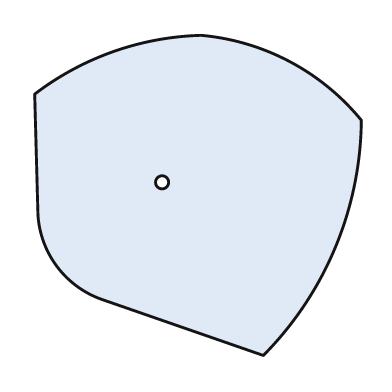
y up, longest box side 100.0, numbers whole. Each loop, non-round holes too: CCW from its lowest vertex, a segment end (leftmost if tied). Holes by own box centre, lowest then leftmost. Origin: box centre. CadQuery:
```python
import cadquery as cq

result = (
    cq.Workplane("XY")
    .moveTo(20.0, -49.0)
    .threePointArc((42.0, -16.0), (50.0, 23.0))
    .threePointArc((28.0, 41.0), (1.0, 49.0))
    .threePointArc((-26.0, 44.0), (-50.0, 31.0))
    .lineTo(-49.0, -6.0)
    .threePointArc((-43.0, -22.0), (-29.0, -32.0))
    .close()
    .moveTo(-11.0, 4.0)
    .circle(2.0)
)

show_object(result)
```